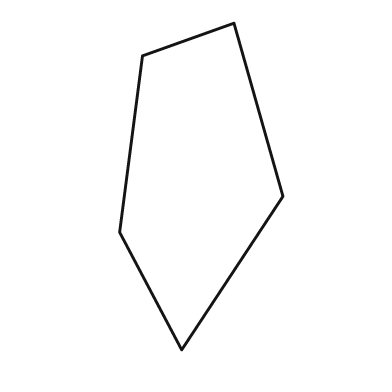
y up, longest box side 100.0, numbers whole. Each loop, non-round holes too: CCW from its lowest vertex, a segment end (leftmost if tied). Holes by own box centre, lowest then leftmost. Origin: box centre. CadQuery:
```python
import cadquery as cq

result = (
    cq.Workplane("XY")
    .moveTo(-6.0, -50.0)
    .lineTo(25.0, -3.0)
    .lineTo(10.0, 50.0)
    .lineTo(-18.0, 40.0)
    .lineTo(-25.0, -14.0)
    .close()
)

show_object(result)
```